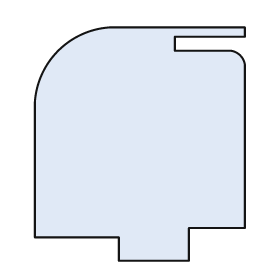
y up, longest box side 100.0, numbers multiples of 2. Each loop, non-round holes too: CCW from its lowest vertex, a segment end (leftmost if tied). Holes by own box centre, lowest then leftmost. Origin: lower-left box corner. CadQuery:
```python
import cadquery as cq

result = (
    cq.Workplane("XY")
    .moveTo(36.0, 0.0)
    .lineTo(66.0, 0.0)
    .lineTo(66.0, 14.0)
    .lineTo(90.0, 14.0)
    .lineTo(90.0, 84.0)
    .threePointArc((88.0, 88.0), (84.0, 90.0))
    .lineTo(60.0, 90.0)
    .lineTo(60.0, 96.0)
    .lineTo(90.0, 96.0)
    .lineTo(90.0, 100.0)
    .lineTo(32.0, 100.0)
    .threePointArc((10.0, 90.0), (0.0, 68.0))
    .lineTo(0.0, 10.0)
    .lineTo(36.0, 10.0)
    .close()
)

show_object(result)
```